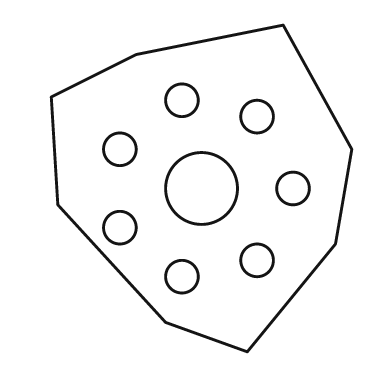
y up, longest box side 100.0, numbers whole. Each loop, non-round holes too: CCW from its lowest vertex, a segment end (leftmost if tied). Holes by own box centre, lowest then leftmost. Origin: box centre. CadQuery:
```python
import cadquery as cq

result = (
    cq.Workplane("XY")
    .moveTo(14.0, -50.0)
    .lineTo(41.0, -17.0)
    .lineTo(46.0, 12.0)
    .lineTo(25.0, 50.0)
    .lineTo(-20.0, 41.0)
    .lineTo(-46.0, 28.0)
    .lineTo(-44.0, -5.0)
    .lineTo(-11.0, -41.0)
    .close()
    .moveTo(-6.0, -27.0)
    .circle(5.0)
    .moveTo(17.0, -22.0)
    .circle(5.0)
    .moveTo(-25.0, -12.0)
    .circle(5.0)
    .moveTo(0.0, 0.0)
    .circle(11.0)
    .moveTo(28.0, 0.0)
    .circle(5.0)
    .moveTo(-25.0, 12.0)
    .circle(5.0)
    .moveTo(17.0, 22.0)
    .circle(5.0)
    .moveTo(-6.0, 27.0)
    .circle(5.0)
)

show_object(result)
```